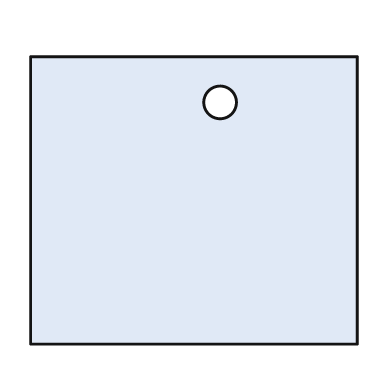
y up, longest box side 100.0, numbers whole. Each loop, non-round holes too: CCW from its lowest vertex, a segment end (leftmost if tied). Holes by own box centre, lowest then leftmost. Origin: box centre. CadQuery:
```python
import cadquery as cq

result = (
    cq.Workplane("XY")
    .moveTo(-50.0, -44.0)
    .lineTo(50.0, -44.0)
    .lineTo(50.0, 44.0)
    .lineTo(-50.0, 44.0)
    .close()
    .moveTo(8.0, 30.0)
    .circle(5.0)
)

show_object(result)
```